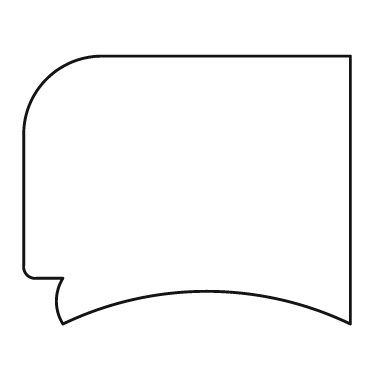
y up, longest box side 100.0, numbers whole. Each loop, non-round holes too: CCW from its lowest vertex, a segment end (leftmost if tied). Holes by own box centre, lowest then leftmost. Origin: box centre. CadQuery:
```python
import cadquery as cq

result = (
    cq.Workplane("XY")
    .moveTo(-38.0, -41.0)
    .threePointArc((6.0, -31.0), (50.0, -41.0))
    .lineTo(50.0, 41.0)
    .lineTo(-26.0, 41.0)
    .threePointArc((-43.0, 34.0), (-50.0, 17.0))
    .lineTo(-50.0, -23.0)
    .threePointArc((-49.0, -26.0), (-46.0, -27.0))
    .lineTo(-38.0, -27.0)
    .threePointArc((-40.0, -34.0), (-38.0, -41.0))
    .close()
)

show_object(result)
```